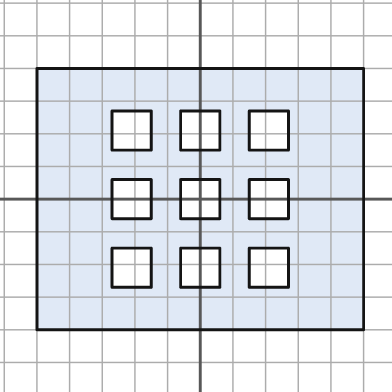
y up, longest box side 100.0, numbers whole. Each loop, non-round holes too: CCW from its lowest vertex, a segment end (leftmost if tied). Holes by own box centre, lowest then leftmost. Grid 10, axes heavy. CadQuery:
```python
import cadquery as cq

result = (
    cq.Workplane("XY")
    .moveTo(-50.0, -40.0)
    .lineTo(50.0, -40.0)
    .lineTo(50.0, 40.0)
    .lineTo(-50.0, 40.0)
    .close()
    .moveTo(-27.0, -27.0)
    .lineTo(-15.0, -27.0)
    .lineTo(-15.0, -15.0)
    .lineTo(-27.0, -15.0)
    .close()
    .moveTo(-6.0, -27.0)
    .lineTo(6.0, -27.0)
    .lineTo(6.0, -15.0)
    .lineTo(-6.0, -15.0)
    .close()
    .moveTo(15.0, -27.0)
    .lineTo(27.0, -27.0)
    .lineTo(27.0, -15.0)
    .lineTo(15.0, -15.0)
    .close()
    .moveTo(-27.0, -6.0)
    .lineTo(-15.0, -6.0)
    .lineTo(-15.0, 6.0)
    .lineTo(-27.0, 6.0)
    .close()
    .moveTo(-6.0, -6.0)
    .lineTo(6.0, -6.0)
    .lineTo(6.0, 6.0)
    .lineTo(-6.0, 6.0)
    .close()
    .moveTo(15.0, -6.0)
    .lineTo(27.0, -6.0)
    .lineTo(27.0, 6.0)
    .lineTo(15.0, 6.0)
    .close()
    .moveTo(-27.0, 15.0)
    .lineTo(-15.0, 15.0)
    .lineTo(-15.0, 27.0)
    .lineTo(-27.0, 27.0)
    .close()
    .moveTo(-6.0, 15.0)
    .lineTo(6.0, 15.0)
    .lineTo(6.0, 27.0)
    .lineTo(-6.0, 27.0)
    .close()
    .moveTo(15.0, 15.0)
    .lineTo(27.0, 15.0)
    .lineTo(27.0, 27.0)
    .lineTo(15.0, 27.0)
    .close()
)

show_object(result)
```